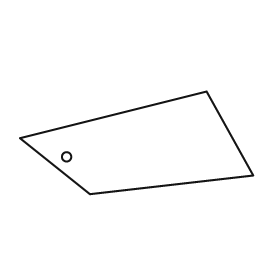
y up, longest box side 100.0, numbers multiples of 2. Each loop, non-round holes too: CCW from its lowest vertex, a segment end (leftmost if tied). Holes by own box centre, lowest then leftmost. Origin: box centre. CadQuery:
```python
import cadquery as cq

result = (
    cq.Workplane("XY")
    .moveTo(-20.0, -22.0)
    .lineTo(50.0, -14.0)
    .lineTo(30.0, 22.0)
    .lineTo(-50.0, 2.0)
    .close()
    .moveTo(-30.0, -6.0)
    .circle(2.0)
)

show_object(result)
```